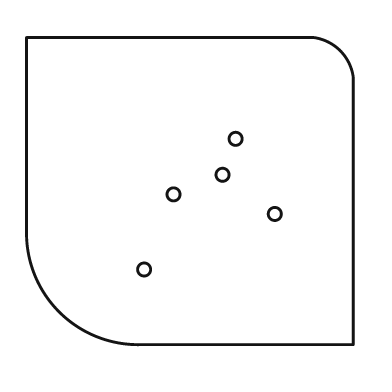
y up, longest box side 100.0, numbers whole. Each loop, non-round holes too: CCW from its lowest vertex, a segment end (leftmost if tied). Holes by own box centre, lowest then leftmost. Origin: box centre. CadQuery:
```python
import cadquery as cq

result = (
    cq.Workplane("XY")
    .moveTo(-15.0, -47.0)
    .lineTo(50.0, -47.0)
    .lineTo(50.0, 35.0)
    .threePointArc((46.0, 43.0), (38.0, 47.0))
    .lineTo(-50.0, 47.0)
    .lineTo(-50.0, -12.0)
    .threePointArc((-40.0, -37.0), (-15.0, -47.0))
    .close()
    .moveTo(-14.0, -24.0)
    .circle(2.0)
    .moveTo(26.0, -7.0)
    .circle(2.0)
    .moveTo(-5.0, -1.0)
    .circle(2.0)
    .moveTo(10.0, 5.0)
    .circle(2.0)
    .moveTo(14.0, 16.0)
    .circle(2.0)
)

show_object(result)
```